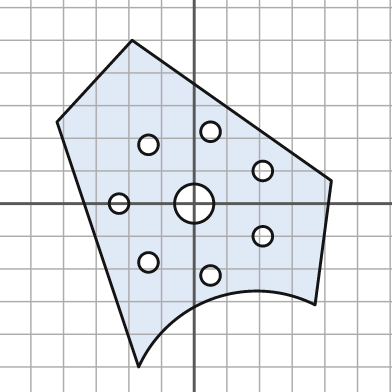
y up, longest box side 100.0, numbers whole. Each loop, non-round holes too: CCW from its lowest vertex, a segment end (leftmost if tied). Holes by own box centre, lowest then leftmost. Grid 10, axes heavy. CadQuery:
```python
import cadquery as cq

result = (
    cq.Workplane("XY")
    .moveTo(-17.0, -50.0)
    .threePointArc((6.0, -29.0), (37.0, -31.0))
    .lineTo(42.0, 7.0)
    .lineTo(-19.0, 50.0)
    .lineTo(-42.0, 25.0)
    .close()
    .moveTo(5.0, -22.0)
    .circle(3.0)
    .moveTo(-14.0, -18.0)
    .circle(3.0)
    .moveTo(21.0, -10.0)
    .circle(3.0)
    .moveTo(-23.0, 0.0)
    .circle(3.0)
    .moveTo(0.0, 0.0)
    .circle(6.0)
    .moveTo(21.0, 10.0)
    .circle(3.0)
    .moveTo(-14.0, 18.0)
    .circle(3.0)
    .moveTo(5.0, 22.0)
    .circle(3.0)
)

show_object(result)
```